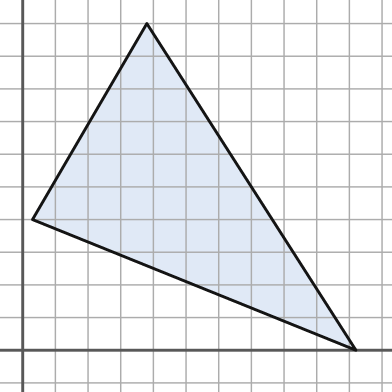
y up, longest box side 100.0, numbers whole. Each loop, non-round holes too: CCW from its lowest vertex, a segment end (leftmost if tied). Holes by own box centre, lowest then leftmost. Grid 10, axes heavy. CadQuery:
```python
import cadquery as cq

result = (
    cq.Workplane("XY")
    .moveTo(102.0, 0.0)
    .lineTo(38.0, 100.0)
    .lineTo(3.0, 40.0)
    .close()
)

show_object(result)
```